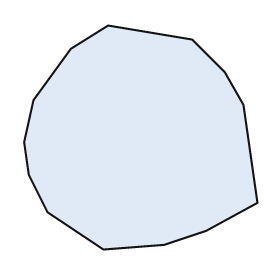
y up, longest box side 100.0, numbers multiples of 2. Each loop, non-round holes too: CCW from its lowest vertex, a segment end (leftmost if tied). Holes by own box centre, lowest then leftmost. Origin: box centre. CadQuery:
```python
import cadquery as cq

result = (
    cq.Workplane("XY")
    .moveTo(-16.0, -48.0)
    .lineTo(10.0, -46.0)
    .lineTo(28.0, -40.0)
    .lineTo(50.0, -28.0)
    .lineTo(44.0, 14.0)
    .lineTo(36.0, 28.0)
    .lineTo(22.0, 42.0)
    .lineTo(-14.0, 48.0)
    .lineTo(-30.0, 38.0)
    .lineTo(-46.0, 16.0)
    .lineTo(-50.0, -2.0)
    .lineTo(-48.0, -16.0)
    .lineTo(-40.0, -32.0)
    .close()
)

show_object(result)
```